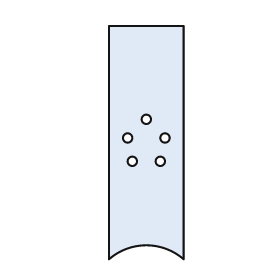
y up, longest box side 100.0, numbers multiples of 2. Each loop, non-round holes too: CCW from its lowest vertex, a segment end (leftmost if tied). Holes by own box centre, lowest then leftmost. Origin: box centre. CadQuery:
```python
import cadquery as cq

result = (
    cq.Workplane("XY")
    .moveTo(-16.0, -50.0)
    .threePointArc((0.0, -44.0), (16.0, -50.0))
    .lineTo(16.0, 50.0)
    .lineTo(-16.0, 50.0)
    .close()
    .moveTo(-6.0, -8.0)
    .circle(2.0)
    .moveTo(6.0, -8.0)
    .circle(2.0)
    .moveTo(-8.0, 2.0)
    .circle(2.0)
    .moveTo(8.0, 2.0)
    .circle(2.0)
    .moveTo(0.0, 10.0)
    .circle(2.0)
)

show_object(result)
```